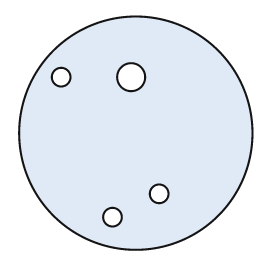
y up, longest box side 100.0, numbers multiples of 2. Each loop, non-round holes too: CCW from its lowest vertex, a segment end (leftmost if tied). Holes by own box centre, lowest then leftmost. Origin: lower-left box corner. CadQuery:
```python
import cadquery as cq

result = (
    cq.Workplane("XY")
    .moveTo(50.0, 50.0)
    .circle(50.0)
    .moveTo(40.0, 14.0)
    .circle(4.0)
    .moveTo(60.0, 24.0)
    .circle(4.0)
    .moveTo(18.0, 74.0)
    .circle(4.0)
    .moveTo(48.0, 74.0)
    .circle(6.0)
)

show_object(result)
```